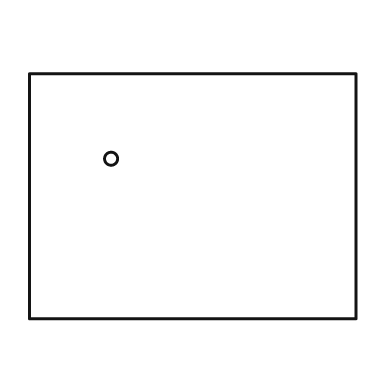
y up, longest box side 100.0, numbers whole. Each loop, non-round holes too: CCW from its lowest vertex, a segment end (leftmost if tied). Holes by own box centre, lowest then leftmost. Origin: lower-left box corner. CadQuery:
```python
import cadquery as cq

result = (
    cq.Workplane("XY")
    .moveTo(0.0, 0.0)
    .lineTo(100.0, 0.0)
    .lineTo(100.0, 75.0)
    .lineTo(0.0, 75.0)
    .close()
    .moveTo(25.0, 49.0)
    .circle(2.0)
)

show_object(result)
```